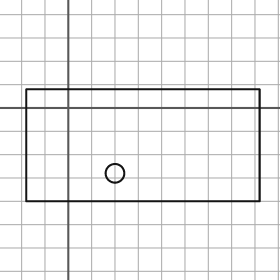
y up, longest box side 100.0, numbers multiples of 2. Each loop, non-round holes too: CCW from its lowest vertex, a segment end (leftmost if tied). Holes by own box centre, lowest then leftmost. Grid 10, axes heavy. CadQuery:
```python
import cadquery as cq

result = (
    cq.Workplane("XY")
    .moveTo(-18.0, -40.0)
    .lineTo(82.0, -40.0)
    .lineTo(82.0, 8.0)
    .lineTo(-18.0, 8.0)
    .close()
    .moveTo(20.0, -28.0)
    .circle(4.0)
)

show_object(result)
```